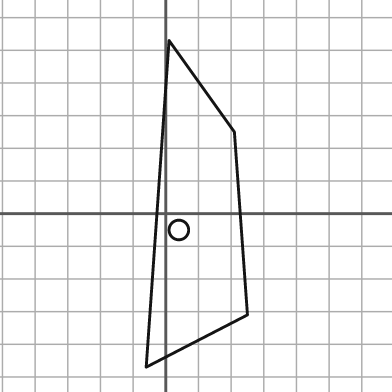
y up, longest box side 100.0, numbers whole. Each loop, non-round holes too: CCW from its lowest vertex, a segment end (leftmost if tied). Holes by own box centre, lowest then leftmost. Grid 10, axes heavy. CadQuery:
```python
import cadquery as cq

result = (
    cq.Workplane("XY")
    .moveTo(-6.0, -47.0)
    .lineTo(25.0, -31.0)
    .lineTo(21.0, 25.0)
    .lineTo(1.0, 53.0)
    .close()
    .moveTo(4.0, -5.0)
    .circle(3.0)
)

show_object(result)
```